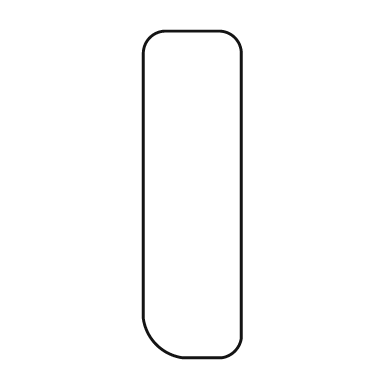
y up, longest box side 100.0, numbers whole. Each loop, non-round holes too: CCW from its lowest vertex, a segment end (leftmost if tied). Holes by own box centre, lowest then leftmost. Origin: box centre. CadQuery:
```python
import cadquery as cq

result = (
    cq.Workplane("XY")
    .moveTo(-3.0, -50.0)
    .lineTo(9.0, -50.0)
    .threePointArc((13.0, -48.0), (15.0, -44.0))
    .lineTo(15.0, 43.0)
    .threePointArc((13.0, 48.0), (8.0, 50.0))
    .lineTo(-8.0, 50.0)
    .threePointArc((-13.0, 48.0), (-15.0, 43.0))
    .lineTo(-15.0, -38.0)
    .threePointArc((-11.0, -46.0), (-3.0, -50.0))
    .close()
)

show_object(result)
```